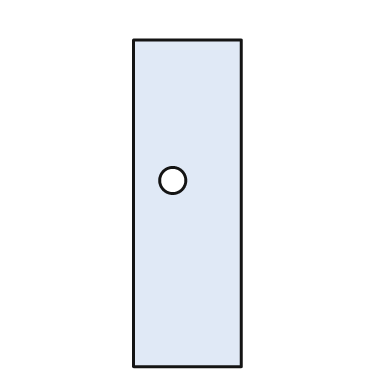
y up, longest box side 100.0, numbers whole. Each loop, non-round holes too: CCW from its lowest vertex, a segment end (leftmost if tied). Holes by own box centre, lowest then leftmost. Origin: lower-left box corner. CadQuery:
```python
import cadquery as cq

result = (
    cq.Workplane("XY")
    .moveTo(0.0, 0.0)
    .lineTo(33.0, 0.0)
    .lineTo(33.0, 100.0)
    .lineTo(0.0, 100.0)
    .close()
    .moveTo(12.0, 57.0)
    .circle(4.0)
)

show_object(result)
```